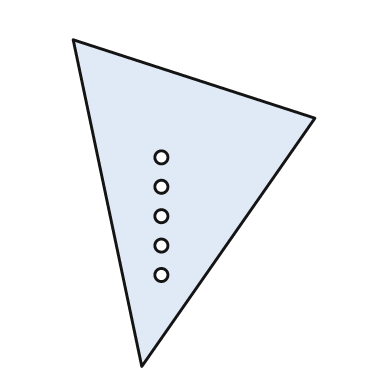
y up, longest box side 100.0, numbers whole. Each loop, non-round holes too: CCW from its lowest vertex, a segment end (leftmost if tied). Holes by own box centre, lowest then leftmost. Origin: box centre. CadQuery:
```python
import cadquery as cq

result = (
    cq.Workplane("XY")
    .moveTo(-16.0, -50.0)
    .lineTo(37.0, 26.0)
    .lineTo(-37.0, 50.0)
    .close()
    .moveTo(-10.0, -22.0)
    .circle(2.0)
    .moveTo(-10.0, -13.0)
    .circle(2.0)
    .moveTo(-10.0, -4.0)
    .circle(2.0)
    .moveTo(-10.0, 5.0)
    .circle(2.0)
    .moveTo(-10.0, 14.0)
    .circle(2.0)
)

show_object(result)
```